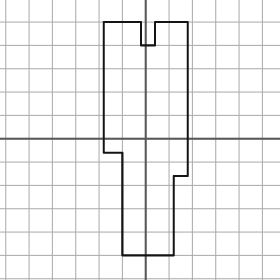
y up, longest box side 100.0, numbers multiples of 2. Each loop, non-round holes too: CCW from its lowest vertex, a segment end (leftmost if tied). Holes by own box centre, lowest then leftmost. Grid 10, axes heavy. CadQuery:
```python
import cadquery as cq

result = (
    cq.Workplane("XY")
    .moveTo(-10.0, -50.0)
    .lineTo(12.0, -50.0)
    .lineTo(12.0, -16.0)
    .lineTo(18.0, -16.0)
    .lineTo(18.0, 50.0)
    .lineTo(4.0, 50.0)
    .lineTo(4.0, 40.0)
    .lineTo(-2.0, 40.0)
    .lineTo(-2.0, 50.0)
    .lineTo(-18.0, 50.0)
    .lineTo(-18.0, -6.0)
    .lineTo(-10.0, -6.0)
    .close()
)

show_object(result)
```